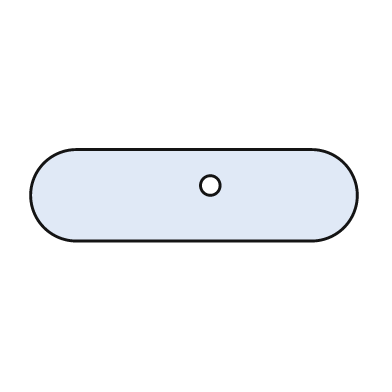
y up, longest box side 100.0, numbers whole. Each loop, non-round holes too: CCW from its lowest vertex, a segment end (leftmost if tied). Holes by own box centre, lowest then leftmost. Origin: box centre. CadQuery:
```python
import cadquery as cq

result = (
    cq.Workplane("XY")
    .moveTo(-36.0, -14.0)
    .lineTo(36.0, -14.0)
    .threePointArc((50.0, 0.0), (36.0, 14.0))
    .lineTo(-36.0, 14.0)
    .threePointArc((-50.0, 0.0), (-36.0, -14.0))
    .close()
    .moveTo(5.0, 3.0)
    .circle(3.0)
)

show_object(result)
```